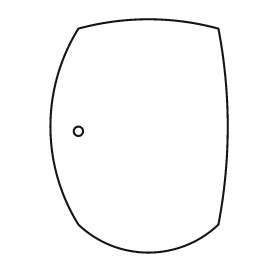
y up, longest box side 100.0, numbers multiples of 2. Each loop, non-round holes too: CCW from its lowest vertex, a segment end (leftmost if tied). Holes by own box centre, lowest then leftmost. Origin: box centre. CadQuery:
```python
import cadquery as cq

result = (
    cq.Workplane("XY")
    .moveTo(-26.0, -38.0)
    .threePointArc((4.0, -50.0), (34.0, -38.0))
    .threePointArc((38.0, 4.0), (34.0, 46.0))
    .threePointArc((4.0, 50.0), (-26.0, 46.0))
    .threePointArc((-38.0, 4.0), (-26.0, -38.0))
    .close()
    .moveTo(-26.0, 2.0)
    .circle(2.0)
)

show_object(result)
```